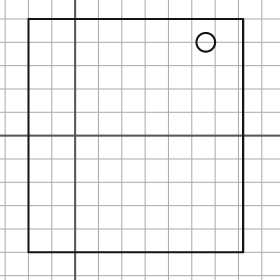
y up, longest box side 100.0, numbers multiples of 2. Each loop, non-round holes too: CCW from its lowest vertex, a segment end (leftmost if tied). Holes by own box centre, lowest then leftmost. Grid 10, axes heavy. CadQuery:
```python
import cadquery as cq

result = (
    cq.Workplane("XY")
    .moveTo(-20.0, -50.0)
    .lineTo(72.0, -50.0)
    .lineTo(72.0, 50.0)
    .lineTo(-20.0, 50.0)
    .close()
    .moveTo(56.0, 40.0)
    .circle(4.0)
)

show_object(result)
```